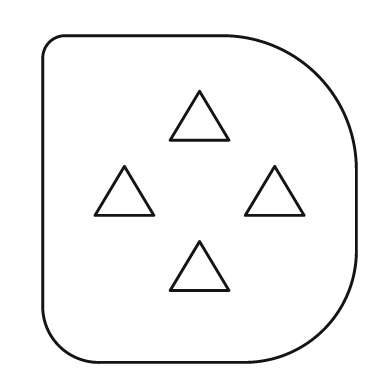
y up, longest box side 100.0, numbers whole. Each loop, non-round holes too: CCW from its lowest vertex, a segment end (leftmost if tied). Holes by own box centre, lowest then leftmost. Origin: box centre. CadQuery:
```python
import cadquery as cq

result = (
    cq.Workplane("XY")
    .moveTo(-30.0, -50.0)
    .lineTo(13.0, -50.0)
    .threePointArc((38.0, -40.0), (48.0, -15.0))
    .lineTo(48.0, 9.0)
    .threePointArc((36.0, 38.0), (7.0, 50.0))
    .lineTo(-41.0, 50.0)
    .threePointArc((-46.0, 48.0), (-48.0, 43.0))
    .lineTo(-48.0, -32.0)
    .threePointArc((-43.0, -45.0), (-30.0, -50.0))
    .close()
    .moveTo(-9.0, -28.0)
    .lineTo(9.0, -28.0)
    .lineTo(0.0, -13.0)
    .close()
    .moveTo(-32.0, -5.0)
    .lineTo(-14.0, -5.0)
    .lineTo(-23.0, 10.0)
    .close()
    .moveTo(14.0, -5.0)
    .lineTo(32.0, -5.0)
    .lineTo(23.0, 10.0)
    .close()
    .moveTo(-9.0, 18.0)
    .lineTo(9.0, 18.0)
    .lineTo(0.0, 33.0)
    .close()
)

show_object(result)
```